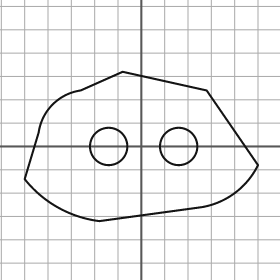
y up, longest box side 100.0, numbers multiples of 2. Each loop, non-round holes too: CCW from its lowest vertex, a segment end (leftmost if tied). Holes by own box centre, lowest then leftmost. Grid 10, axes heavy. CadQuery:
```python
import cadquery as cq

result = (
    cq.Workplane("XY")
    .moveTo(-18.0, -32.0)
    .lineTo(26.0, -26.0)
    .threePointArc((40.0, -20.0), (50.0, -8.0))
    .lineTo(28.0, 24.0)
    .lineTo(-8.0, 32.0)
    .lineTo(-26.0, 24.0)
    .threePointArc((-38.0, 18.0), (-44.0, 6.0))
    .lineTo(-50.0, -14.0)
    .threePointArc((-36.0, -26.0), (-18.0, -32.0))
    .close()
    .moveTo(-14.0, 0.0)
    .circle(8.0)
    .moveTo(16.0, 0.0)
    .circle(8.0)
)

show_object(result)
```